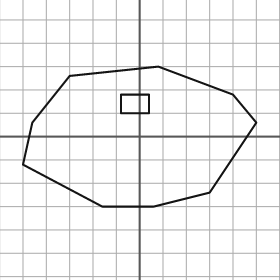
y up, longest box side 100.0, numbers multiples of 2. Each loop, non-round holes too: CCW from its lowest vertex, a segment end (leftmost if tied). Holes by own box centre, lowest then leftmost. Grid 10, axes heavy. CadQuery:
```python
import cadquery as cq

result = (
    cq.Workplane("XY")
    .moveTo(-16.0, -30.0)
    .lineTo(6.0, -30.0)
    .lineTo(30.0, -24.0)
    .lineTo(50.0, 6.0)
    .lineTo(40.0, 18.0)
    .lineTo(8.0, 30.0)
    .lineTo(-30.0, 26.0)
    .lineTo(-46.0, 6.0)
    .lineTo(-50.0, -12.0)
    .close()
    .moveTo(-8.0, 10.0)
    .lineTo(4.0, 10.0)
    .lineTo(4.0, 18.0)
    .lineTo(-8.0, 18.0)
    .close()
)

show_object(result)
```